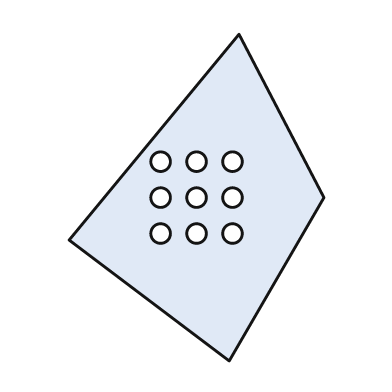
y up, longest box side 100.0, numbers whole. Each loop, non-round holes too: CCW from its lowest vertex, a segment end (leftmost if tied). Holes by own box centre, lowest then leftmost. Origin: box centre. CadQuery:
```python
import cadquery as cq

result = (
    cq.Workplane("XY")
    .moveTo(10.0, -50.0)
    .lineTo(39.0, 0.0)
    .lineTo(13.0, 50.0)
    .lineTo(-39.0, -13.0)
    .close()
    .moveTo(-11.0, -11.0)
    .circle(3.0)
    .moveTo(0.0, -11.0)
    .circle(3.0)
    .moveTo(11.0, -11.0)
    .circle(3.0)
    .moveTo(-11.0, 0.0)
    .circle(3.0)
    .moveTo(0.0, 0.0)
    .circle(3.0)
    .moveTo(11.0, 0.0)
    .circle(3.0)
    .moveTo(-11.0, 11.0)
    .circle(3.0)
    .moveTo(0.0, 11.0)
    .circle(3.0)
    .moveTo(11.0, 11.0)
    .circle(3.0)
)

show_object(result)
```